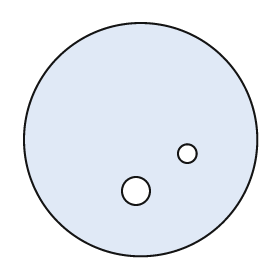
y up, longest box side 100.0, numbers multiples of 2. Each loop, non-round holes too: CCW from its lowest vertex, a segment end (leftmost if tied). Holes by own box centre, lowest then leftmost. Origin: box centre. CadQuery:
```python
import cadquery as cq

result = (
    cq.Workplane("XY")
    .moveTo(0.0, 0.0)
    .circle(50.0)
    .moveTo(-2.0, -22.0)
    .circle(6.0)
    .moveTo(20.0, -6.0)
    .circle(4.0)
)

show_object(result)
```